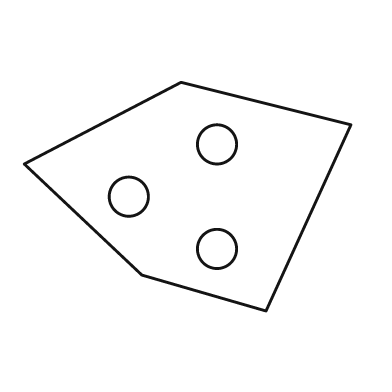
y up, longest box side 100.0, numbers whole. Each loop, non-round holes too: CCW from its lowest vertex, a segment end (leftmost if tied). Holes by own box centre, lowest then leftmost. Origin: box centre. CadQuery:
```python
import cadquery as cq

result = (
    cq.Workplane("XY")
    .moveTo(24.0, -35.0)
    .lineTo(50.0, 22.0)
    .lineTo(-2.0, 35.0)
    .lineTo(-50.0, 10.0)
    .lineTo(-14.0, -24.0)
    .close()
    .moveTo(9.0, -16.0)
    .circle(6.0)
    .moveTo(-18.0, 0.0)
    .circle(6.0)
    .moveTo(9.0, 16.0)
    .circle(6.0)
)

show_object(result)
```